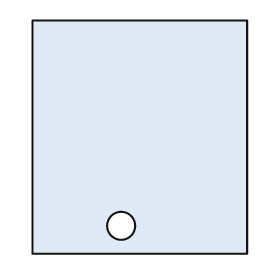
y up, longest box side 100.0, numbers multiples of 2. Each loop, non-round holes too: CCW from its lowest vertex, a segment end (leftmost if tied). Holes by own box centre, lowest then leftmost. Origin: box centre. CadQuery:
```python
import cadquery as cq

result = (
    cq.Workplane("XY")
    .moveTo(-46.0, -50.0)
    .lineTo(46.0, -50.0)
    .lineTo(46.0, 50.0)
    .lineTo(-46.0, 50.0)
    .close()
    .moveTo(-8.0, -38.0)
    .circle(6.0)
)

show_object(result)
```